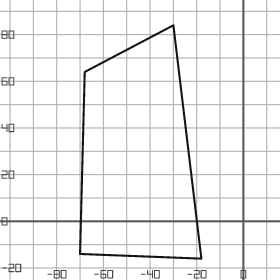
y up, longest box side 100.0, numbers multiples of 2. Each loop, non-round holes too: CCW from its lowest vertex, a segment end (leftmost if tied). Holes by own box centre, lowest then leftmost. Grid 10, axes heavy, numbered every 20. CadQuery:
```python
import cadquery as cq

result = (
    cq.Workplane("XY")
    .moveTo(-18.0, -16.0)
    .lineTo(-30.0, 84.0)
    .lineTo(-68.0, 64.0)
    .lineTo(-70.0, -14.0)
    .close()
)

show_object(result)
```